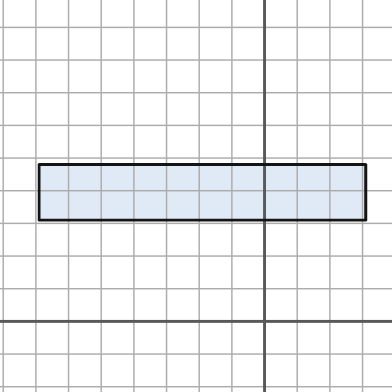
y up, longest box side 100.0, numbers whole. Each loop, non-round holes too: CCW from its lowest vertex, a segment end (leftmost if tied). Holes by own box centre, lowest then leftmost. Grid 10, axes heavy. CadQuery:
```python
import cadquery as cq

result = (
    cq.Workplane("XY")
    .moveTo(-69.0, 31.0)
    .lineTo(31.0, 31.0)
    .lineTo(31.0, 48.0)
    .lineTo(-69.0, 48.0)
    .close()
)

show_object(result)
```